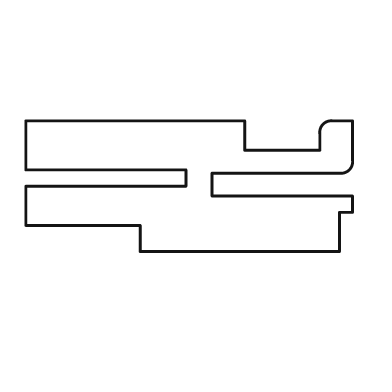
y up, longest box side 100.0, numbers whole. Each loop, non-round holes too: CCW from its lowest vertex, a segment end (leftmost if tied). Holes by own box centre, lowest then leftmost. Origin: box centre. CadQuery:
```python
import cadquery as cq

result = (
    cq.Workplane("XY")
    .moveTo(-15.0, -20.0)
    .lineTo(46.0, -20.0)
    .lineTo(46.0, -8.0)
    .lineTo(50.0, -8.0)
    .lineTo(50.0, -3.0)
    .lineTo(7.0, -3.0)
    .lineTo(7.0, 4.0)
    .lineTo(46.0, 4.0)
    .threePointArc((49.0, 5.0), (50.0, 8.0))
    .lineTo(50.0, 20.0)
    .lineTo(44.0, 20.0)
    .threePointArc((41.0, 19.0), (40.0, 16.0))
    .lineTo(40.0, 11.0)
    .lineTo(17.0, 11.0)
    .lineTo(17.0, 20.0)
    .lineTo(-50.0, 20.0)
    .lineTo(-50.0, 5.0)
    .lineTo(-1.0, 5.0)
    .lineTo(-1.0, 0.0)
    .lineTo(-50.0, 0.0)
    .lineTo(-50.0, -12.0)
    .lineTo(-15.0, -12.0)
    .close()
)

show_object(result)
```